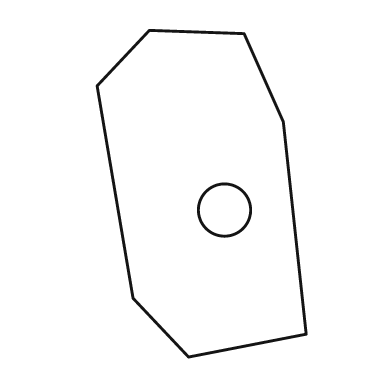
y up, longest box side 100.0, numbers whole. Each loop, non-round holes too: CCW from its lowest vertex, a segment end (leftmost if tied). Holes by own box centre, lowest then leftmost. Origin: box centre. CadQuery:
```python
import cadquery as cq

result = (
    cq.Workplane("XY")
    .moveTo(-4.0, -50.0)
    .lineTo(32.0, -43.0)
    .lineTo(25.0, 22.0)
    .lineTo(13.0, 49.0)
    .lineTo(-16.0, 50.0)
    .lineTo(-32.0, 33.0)
    .lineTo(-21.0, -32.0)
    .close()
    .moveTo(7.0, -5.0)
    .circle(8.0)
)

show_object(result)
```